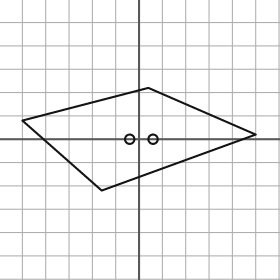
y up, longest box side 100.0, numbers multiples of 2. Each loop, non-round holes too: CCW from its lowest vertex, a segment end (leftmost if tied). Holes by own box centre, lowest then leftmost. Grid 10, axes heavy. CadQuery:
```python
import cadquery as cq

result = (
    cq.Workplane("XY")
    .moveTo(-16.0, -22.0)
    .lineTo(50.0, 2.0)
    .lineTo(4.0, 22.0)
    .lineTo(-50.0, 8.0)
    .close()
    .moveTo(-4.0, 0.0)
    .circle(2.0)
    .moveTo(6.0, 0.0)
    .circle(2.0)
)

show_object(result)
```